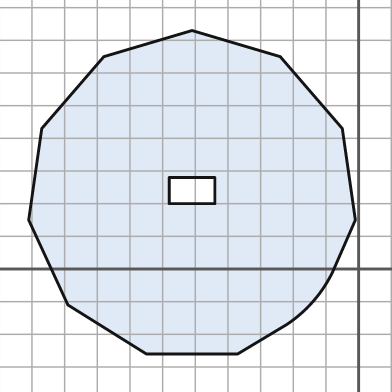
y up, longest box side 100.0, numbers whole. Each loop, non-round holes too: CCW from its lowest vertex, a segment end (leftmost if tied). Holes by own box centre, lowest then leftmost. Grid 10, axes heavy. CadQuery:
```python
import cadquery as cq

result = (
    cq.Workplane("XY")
    .moveTo(-65.0, -26.0)
    .lineTo(-37.0, -26.0)
    .lineTo(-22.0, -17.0)
    .threePointArc((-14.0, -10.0), (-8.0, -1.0))
    .lineTo(-1.0, 15.0)
    .lineTo(-5.0, 43.0)
    .lineTo(-24.0, 65.0)
    .lineTo(-51.0, 73.0)
    .lineTo(-78.0, 65.0)
    .lineTo(-97.0, 43.0)
    .lineTo(-101.0, 15.0)
    .lineTo(-89.0, -11.0)
    .close()
    .moveTo(-58.0, 20.0)
    .lineTo(-44.0, 20.0)
    .lineTo(-44.0, 28.0)
    .lineTo(-58.0, 28.0)
    .close()
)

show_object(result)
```